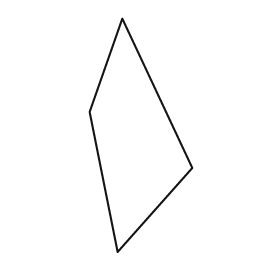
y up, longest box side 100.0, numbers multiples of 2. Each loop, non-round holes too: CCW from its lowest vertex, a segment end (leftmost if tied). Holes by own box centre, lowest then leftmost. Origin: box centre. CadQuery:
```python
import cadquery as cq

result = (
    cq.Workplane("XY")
    .moveTo(-10.0, -50.0)
    .lineTo(22.0, -14.0)
    .lineTo(-8.0, 50.0)
    .lineTo(-22.0, 10.0)
    .close()
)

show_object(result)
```